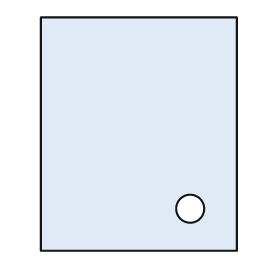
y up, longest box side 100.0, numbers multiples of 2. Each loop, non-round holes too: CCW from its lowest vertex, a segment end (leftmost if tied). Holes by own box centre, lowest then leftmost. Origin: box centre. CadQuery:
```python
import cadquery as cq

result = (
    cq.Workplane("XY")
    .moveTo(-42.0, -50.0)
    .lineTo(42.0, -50.0)
    .lineTo(42.0, 50.0)
    .lineTo(-42.0, 50.0)
    .close()
    .moveTo(22.0, -32.0)
    .circle(6.0)
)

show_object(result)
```